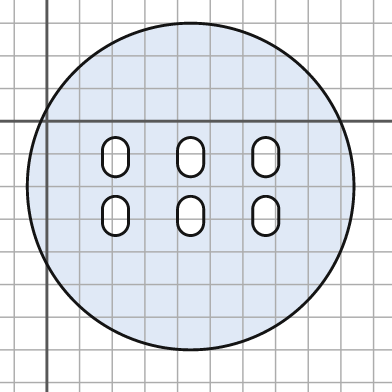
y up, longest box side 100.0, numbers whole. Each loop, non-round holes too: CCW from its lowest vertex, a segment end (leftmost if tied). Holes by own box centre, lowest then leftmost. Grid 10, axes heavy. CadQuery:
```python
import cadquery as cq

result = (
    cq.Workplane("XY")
    .moveTo(44.0, -20.0)
    .circle(50.0)
    .moveTo(17.0, -31.0)
    .threePointArc((21.0, -35.0), (25.0, -31.0))
    .lineTo(25.0, -27.0)
    .threePointArc((21.0, -23.0), (17.0, -27.0))
    .close()
    .moveTo(40.0, -31.0)
    .threePointArc((44.0, -35.0), (48.0, -31.0))
    .lineTo(48.0, -27.0)
    .threePointArc((44.0, -23.0), (40.0, -27.0))
    .close()
    .moveTo(63.0, -31.0)
    .threePointArc((67.0, -35.0), (71.0, -31.0))
    .lineTo(71.0, -27.0)
    .threePointArc((67.0, -23.0), (63.0, -27.0))
    .close()
    .moveTo(17.0, -13.0)
    .threePointArc((21.0, -17.0), (25.0, -13.0))
    .lineTo(25.0, -9.0)
    .threePointArc((21.0, -5.0), (17.0, -9.0))
    .close()
    .moveTo(40.0, -13.0)
    .threePointArc((44.0, -17.0), (48.0, -13.0))
    .lineTo(48.0, -9.0)
    .threePointArc((44.0, -5.0), (40.0, -9.0))
    .close()
    .moveTo(63.0, -13.0)
    .threePointArc((67.0, -17.0), (71.0, -13.0))
    .lineTo(71.0, -9.0)
    .threePointArc((67.0, -5.0), (63.0, -9.0))
    .close()
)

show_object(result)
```